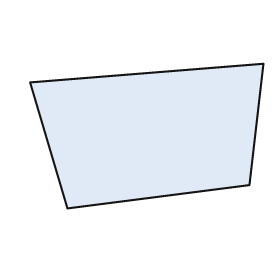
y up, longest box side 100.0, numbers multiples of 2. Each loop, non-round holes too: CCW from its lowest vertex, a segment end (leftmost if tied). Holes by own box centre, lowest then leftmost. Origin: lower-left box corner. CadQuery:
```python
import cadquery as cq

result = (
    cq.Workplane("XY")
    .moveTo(16.0, 0.0)
    .lineTo(94.0, 10.0)
    .lineTo(100.0, 62.0)
    .lineTo(0.0, 54.0)
    .close()
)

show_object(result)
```